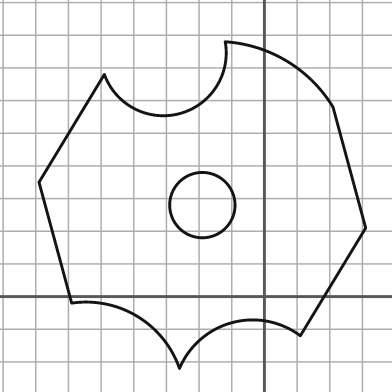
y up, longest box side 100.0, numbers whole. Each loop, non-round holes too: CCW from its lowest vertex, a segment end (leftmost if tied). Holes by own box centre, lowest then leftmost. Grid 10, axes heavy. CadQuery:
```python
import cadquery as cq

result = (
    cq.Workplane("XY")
    .moveTo(-26.0, -22.0)
    .threePointArc((-10.0, -8.0), (11.0, -12.0))
    .lineTo(31.0, 21.0)
    .lineTo(21.0, 58.0)
    .threePointArc((7.0, 72.0), (-12.0, 78.0))
    .threePointArc((-26.0, 56.0), (-49.0, 68.0))
    .lineTo(-69.0, 35.0)
    .lineTo(-59.0, -2.0)
    .threePointArc((-39.0, -6.0), (-26.0, -22.0))
    .close()
    .moveTo(-19.0, 28.0)
    .circle(10.0)
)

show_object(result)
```